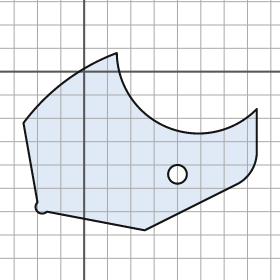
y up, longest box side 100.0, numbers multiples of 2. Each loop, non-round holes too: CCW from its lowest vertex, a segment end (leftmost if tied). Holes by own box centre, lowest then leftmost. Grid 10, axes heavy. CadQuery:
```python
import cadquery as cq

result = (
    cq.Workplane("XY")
    .moveTo(26.0, -68.0)
    .lineTo(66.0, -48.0)
    .threePointArc((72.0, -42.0), (74.0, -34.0))
    .lineTo(74.0, -16.0)
    .threePointArc((36.0, -24.0), (14.0, 8.0))
    .threePointArc((-8.0, -4.0), (-26.0, -22.0))
    .lineTo(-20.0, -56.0)
    .threePointArc((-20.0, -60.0), (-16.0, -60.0))
    .close()
    .moveTo(40.0, -44.0)
    .circle(4.0)
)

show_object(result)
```